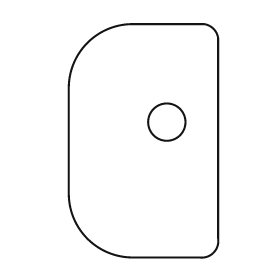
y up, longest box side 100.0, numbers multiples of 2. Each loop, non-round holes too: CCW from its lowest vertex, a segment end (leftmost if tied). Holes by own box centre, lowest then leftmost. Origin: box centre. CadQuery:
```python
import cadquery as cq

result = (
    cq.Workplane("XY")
    .moveTo(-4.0, -50.0)
    .lineTo(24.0, -50.0)
    .threePointArc((30.0, -48.0), (32.0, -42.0))
    .lineTo(32.0, 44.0)
    .threePointArc((30.0, 48.0), (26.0, 50.0))
    .lineTo(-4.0, 50.0)
    .threePointArc((-24.0, 42.0), (-32.0, 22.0))
    .lineTo(-32.0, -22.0)
    .threePointArc((-24.0, -42.0), (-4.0, -50.0))
    .close()
    .moveTo(10.0, 8.0)
    .circle(8.0)
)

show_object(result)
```